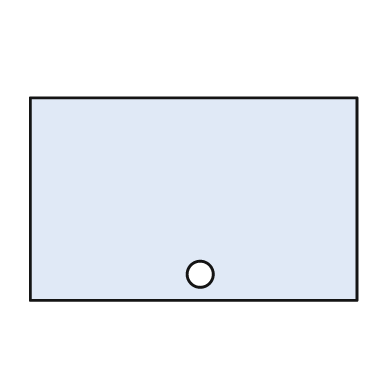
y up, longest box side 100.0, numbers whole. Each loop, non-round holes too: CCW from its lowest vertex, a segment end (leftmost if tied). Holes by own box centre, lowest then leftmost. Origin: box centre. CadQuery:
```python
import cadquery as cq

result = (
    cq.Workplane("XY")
    .moveTo(-50.0, -31.0)
    .lineTo(50.0, -31.0)
    .lineTo(50.0, 31.0)
    .lineTo(-50.0, 31.0)
    .close()
    .moveTo(2.0, -23.0)
    .circle(4.0)
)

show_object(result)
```